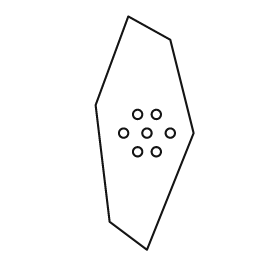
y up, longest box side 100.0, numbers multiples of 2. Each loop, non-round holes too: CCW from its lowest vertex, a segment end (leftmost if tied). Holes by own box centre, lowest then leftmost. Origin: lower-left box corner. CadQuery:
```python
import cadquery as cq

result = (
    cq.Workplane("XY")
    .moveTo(22.0, 0.0)
    .lineTo(42.0, 50.0)
    .lineTo(32.0, 90.0)
    .lineTo(14.0, 100.0)
    .lineTo(0.0, 62.0)
    .lineTo(6.0, 12.0)
    .close()
    .moveTo(18.0, 42.0)
    .circle(2.0)
    .moveTo(26.0, 42.0)
    .circle(2.0)
    .moveTo(12.0, 50.0)
    .circle(2.0)
    .moveTo(22.0, 50.0)
    .circle(2.0)
    .moveTo(32.0, 50.0)
    .circle(2.0)
    .moveTo(18.0, 58.0)
    .circle(2.0)
    .moveTo(26.0, 58.0)
    .circle(2.0)
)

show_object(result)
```